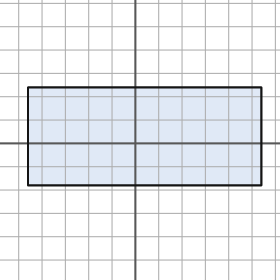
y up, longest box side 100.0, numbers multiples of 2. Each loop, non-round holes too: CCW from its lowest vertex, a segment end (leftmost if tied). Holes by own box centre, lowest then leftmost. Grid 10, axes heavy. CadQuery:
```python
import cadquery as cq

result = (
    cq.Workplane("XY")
    .moveTo(-46.0, -18.0)
    .lineTo(54.0, -18.0)
    .lineTo(54.0, 24.0)
    .lineTo(-46.0, 24.0)
    .close()
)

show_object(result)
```